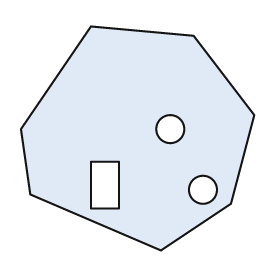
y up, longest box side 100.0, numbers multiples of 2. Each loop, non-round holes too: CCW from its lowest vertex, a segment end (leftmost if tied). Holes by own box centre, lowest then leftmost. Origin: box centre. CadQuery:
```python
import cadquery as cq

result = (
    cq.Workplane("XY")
    .moveTo(10.0, -48.0)
    .lineTo(40.0, -28.0)
    .lineTo(50.0, 10.0)
    .lineTo(24.0, 44.0)
    .lineTo(-20.0, 48.0)
    .lineTo(-50.0, 4.0)
    .lineTo(-46.0, -24.0)
    .close()
    .moveTo(28.0, -22.0)
    .circle(6.0)
    .moveTo(-20.0, -30.0)
    .lineTo(-8.0, -30.0)
    .lineTo(-8.0, -10.0)
    .lineTo(-20.0, -10.0)
    .close()
    .moveTo(14.0, 4.0)
    .circle(6.0)
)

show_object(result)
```